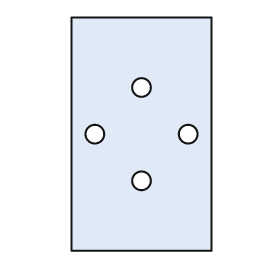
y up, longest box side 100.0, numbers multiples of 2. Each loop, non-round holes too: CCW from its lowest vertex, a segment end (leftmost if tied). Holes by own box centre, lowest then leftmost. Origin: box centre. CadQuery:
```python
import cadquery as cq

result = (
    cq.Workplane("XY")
    .moveTo(-30.0, -50.0)
    .lineTo(30.0, -50.0)
    .lineTo(30.0, 50.0)
    .lineTo(-30.0, 50.0)
    .close()
    .moveTo(0.0, -20.0)
    .circle(4.0)
    .moveTo(-20.0, 0.0)
    .circle(4.0)
    .moveTo(20.0, 0.0)
    .circle(4.0)
    .moveTo(0.0, 20.0)
    .circle(4.0)
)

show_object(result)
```